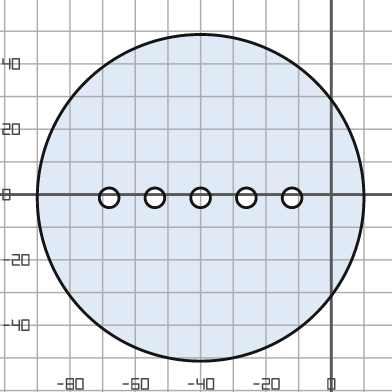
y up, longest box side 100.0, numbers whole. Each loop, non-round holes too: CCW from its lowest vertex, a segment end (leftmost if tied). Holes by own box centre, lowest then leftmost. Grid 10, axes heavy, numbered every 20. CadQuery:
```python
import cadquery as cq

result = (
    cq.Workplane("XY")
    .moveTo(-40.0, -1.0)
    .circle(50.0)
    .moveTo(-68.0, -1.0)
    .circle(3.0)
    .moveTo(-54.0, -1.0)
    .circle(3.0)
    .moveTo(-40.0, -1.0)
    .circle(3.0)
    .moveTo(-26.0, -1.0)
    .circle(3.0)
    .moveTo(-12.0, -1.0)
    .circle(3.0)
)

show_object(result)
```